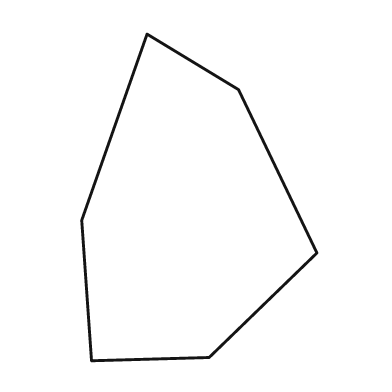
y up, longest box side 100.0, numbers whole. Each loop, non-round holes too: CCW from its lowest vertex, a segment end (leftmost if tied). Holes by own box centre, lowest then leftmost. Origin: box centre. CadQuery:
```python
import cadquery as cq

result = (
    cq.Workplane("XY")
    .moveTo(-33.0, -50.0)
    .lineTo(3.0, -49.0)
    .lineTo(36.0, -17.0)
    .lineTo(12.0, 33.0)
    .lineTo(-16.0, 50.0)
    .lineTo(-36.0, -7.0)
    .close()
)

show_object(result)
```